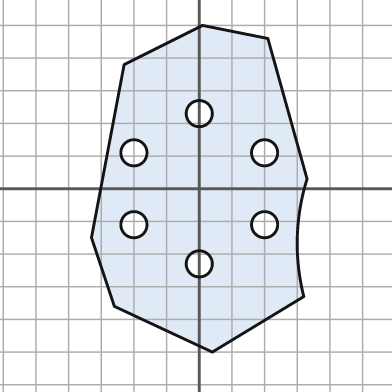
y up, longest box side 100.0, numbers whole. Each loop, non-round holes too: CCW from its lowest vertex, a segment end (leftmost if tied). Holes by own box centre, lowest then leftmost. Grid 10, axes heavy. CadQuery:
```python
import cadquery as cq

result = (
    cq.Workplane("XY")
    .moveTo(4.0, -50.0)
    .lineTo(32.0, -33.0)
    .threePointArc((30.0, -15.0), (33.0, 3.0))
    .lineTo(21.0, 46.0)
    .lineTo(1.0, 50.0)
    .lineTo(-23.0, 38.0)
    .lineTo(-33.0, -15.0)
    .lineTo(-26.0, -36.0)
    .close()
    .moveTo(0.0, -23.0)
    .circle(4.0)
    .moveTo(-20.0, -11.0)
    .circle(4.0)
    .moveTo(20.0, -11.0)
    .circle(4.0)
    .moveTo(-20.0, 11.0)
    .circle(4.0)
    .moveTo(20.0, 11.0)
    .circle(4.0)
    .moveTo(0.0, 23.0)
    .circle(4.0)
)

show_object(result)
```